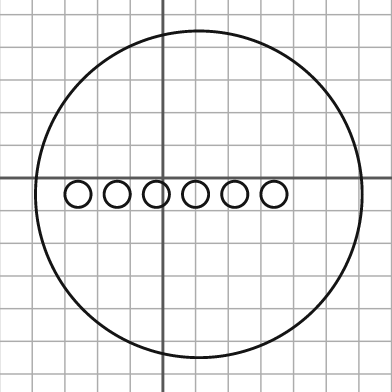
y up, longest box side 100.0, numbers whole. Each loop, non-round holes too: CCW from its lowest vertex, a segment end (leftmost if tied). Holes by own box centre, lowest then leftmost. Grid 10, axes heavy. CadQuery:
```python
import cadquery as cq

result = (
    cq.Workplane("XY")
    .moveTo(11.0, -5.0)
    .circle(50.0)
    .moveTo(-26.0, -5.0)
    .circle(4.0)
    .moveTo(-14.0, -5.0)
    .circle(4.0)
    .moveTo(-2.0, -5.0)
    .circle(4.0)
    .moveTo(10.0, -5.0)
    .circle(4.0)
    .moveTo(22.0, -5.0)
    .circle(4.0)
    .moveTo(34.0, -5.0)
    .circle(4.0)
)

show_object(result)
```